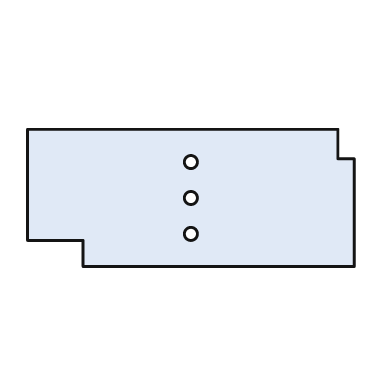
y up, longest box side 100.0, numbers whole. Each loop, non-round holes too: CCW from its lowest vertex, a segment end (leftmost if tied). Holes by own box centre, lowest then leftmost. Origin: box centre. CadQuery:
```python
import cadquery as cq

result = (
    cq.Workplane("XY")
    .moveTo(-33.0, -21.0)
    .lineTo(50.0, -21.0)
    .lineTo(50.0, 12.0)
    .lineTo(45.0, 12.0)
    .lineTo(45.0, 21.0)
    .lineTo(-50.0, 21.0)
    .lineTo(-50.0, -13.0)
    .lineTo(-33.0, -13.0)
    .close()
    .moveTo(0.0, -11.0)
    .circle(2.0)
    .moveTo(0.0, 0.0)
    .circle(2.0)
    .moveTo(0.0, 11.0)
    .circle(2.0)
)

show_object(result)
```